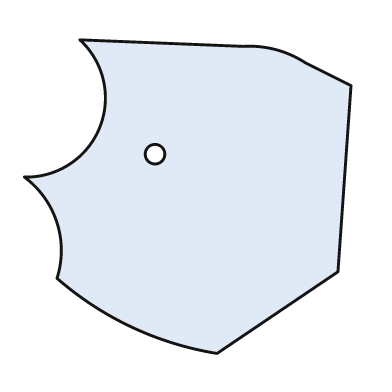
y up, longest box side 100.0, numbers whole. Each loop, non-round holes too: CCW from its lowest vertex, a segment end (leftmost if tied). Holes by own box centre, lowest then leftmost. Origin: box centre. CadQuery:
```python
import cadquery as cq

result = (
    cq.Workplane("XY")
    .moveTo(9.0, -48.0)
    .lineTo(46.0, -23.0)
    .lineTo(50.0, 34.0)
    .lineTo(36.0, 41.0)
    .threePointArc((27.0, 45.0), (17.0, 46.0))
    .lineTo(-33.0, 48.0)
    .threePointArc((-27.0, 21.0), (-50.0, 6.0))
    .threePointArc((-40.0, -8.0), (-40.0, -25.0))
    .threePointArc((-17.0, -40.0), (9.0, -48.0))
    .close()
    .moveTo(-10.0, 13.0)
    .circle(3.0)
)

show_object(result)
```